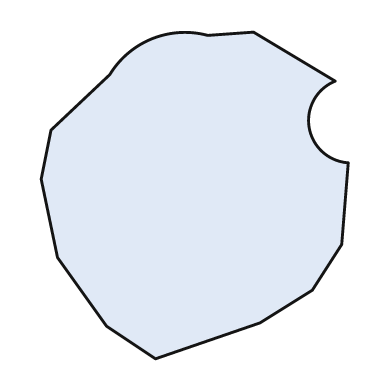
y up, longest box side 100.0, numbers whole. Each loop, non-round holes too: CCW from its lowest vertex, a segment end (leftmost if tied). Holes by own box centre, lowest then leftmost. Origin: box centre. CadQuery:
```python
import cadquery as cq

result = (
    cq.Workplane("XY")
    .moveTo(-12.0, -50.0)
    .lineTo(20.0, -39.0)
    .lineTo(36.0, -29.0)
    .lineTo(45.0, -15.0)
    .lineTo(47.0, 10.0)
    .threePointArc((35.0, 21.0), (43.0, 35.0))
    .lineTo(18.0, 50.0)
    .lineTo(4.0, 49.0)
    .threePointArc((-13.0, 48.0), (-26.0, 37.0))
    .lineTo(-44.0, 20.0)
    .lineTo(-47.0, 5.0)
    .lineTo(-42.0, -19.0)
    .lineTo(-27.0, -40.0)
    .close()
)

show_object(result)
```